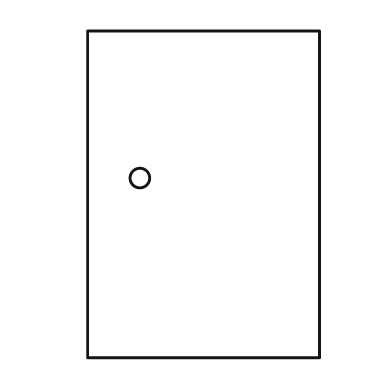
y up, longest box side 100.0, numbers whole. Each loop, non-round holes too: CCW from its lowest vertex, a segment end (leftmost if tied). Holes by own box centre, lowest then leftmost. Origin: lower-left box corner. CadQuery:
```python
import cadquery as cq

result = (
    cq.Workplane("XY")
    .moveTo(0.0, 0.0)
    .lineTo(71.0, 0.0)
    .lineTo(71.0, 100.0)
    .lineTo(0.0, 100.0)
    .close()
    .moveTo(16.0, 55.0)
    .circle(3.0)
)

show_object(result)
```